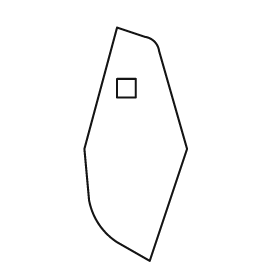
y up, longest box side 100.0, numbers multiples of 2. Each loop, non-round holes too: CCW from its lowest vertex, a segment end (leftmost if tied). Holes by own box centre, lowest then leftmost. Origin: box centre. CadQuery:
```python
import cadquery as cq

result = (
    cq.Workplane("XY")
    .moveTo(6.0, -50.0)
    .lineTo(22.0, -2.0)
    .lineTo(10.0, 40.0)
    .threePointArc((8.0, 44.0), (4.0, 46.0))
    .lineTo(-8.0, 50.0)
    .lineTo(-22.0, -2.0)
    .lineTo(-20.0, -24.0)
    .threePointArc((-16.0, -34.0), (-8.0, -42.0))
    .close()
    .moveTo(-8.0, 20.0)
    .lineTo(0.0, 20.0)
    .lineTo(0.0, 28.0)
    .lineTo(-8.0, 28.0)
    .close()
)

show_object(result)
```